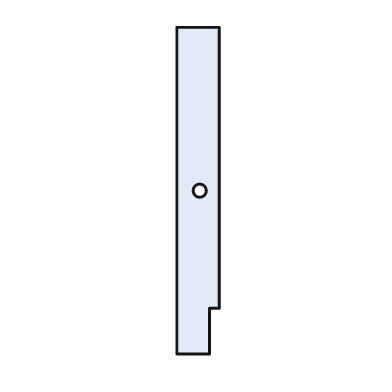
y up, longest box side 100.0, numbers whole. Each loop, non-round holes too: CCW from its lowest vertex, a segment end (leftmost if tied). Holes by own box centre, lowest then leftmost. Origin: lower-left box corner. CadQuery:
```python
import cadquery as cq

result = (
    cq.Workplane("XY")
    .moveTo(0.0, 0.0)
    .lineTo(10.0, 0.0)
    .lineTo(10.0, 14.0)
    .lineTo(13.0, 14.0)
    .lineTo(13.0, 100.0)
    .lineTo(0.0, 100.0)
    .close()
    .moveTo(7.0, 50.0)
    .circle(2.0)
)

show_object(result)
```